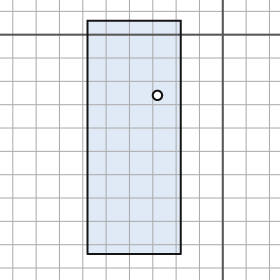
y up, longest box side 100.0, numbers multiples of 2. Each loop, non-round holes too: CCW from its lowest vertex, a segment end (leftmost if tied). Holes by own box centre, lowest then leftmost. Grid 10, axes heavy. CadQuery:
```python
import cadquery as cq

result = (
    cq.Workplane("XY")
    .moveTo(-58.0, -94.0)
    .lineTo(-18.0, -94.0)
    .lineTo(-18.0, 6.0)
    .lineTo(-58.0, 6.0)
    .close()
    .moveTo(-28.0, -26.0)
    .circle(2.0)
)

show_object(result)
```